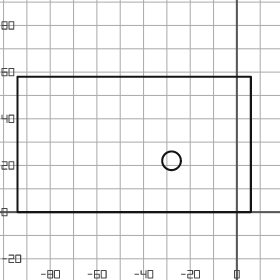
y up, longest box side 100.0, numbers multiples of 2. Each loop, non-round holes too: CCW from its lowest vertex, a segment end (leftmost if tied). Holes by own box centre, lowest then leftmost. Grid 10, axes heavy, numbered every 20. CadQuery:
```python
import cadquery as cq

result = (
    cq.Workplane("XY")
    .moveTo(-94.0, 0.0)
    .lineTo(6.0, 0.0)
    .lineTo(6.0, 58.0)
    .lineTo(-94.0, 58.0)
    .close()
    .moveTo(-28.0, 22.0)
    .circle(4.0)
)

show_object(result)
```